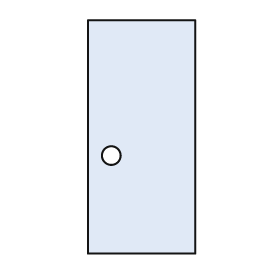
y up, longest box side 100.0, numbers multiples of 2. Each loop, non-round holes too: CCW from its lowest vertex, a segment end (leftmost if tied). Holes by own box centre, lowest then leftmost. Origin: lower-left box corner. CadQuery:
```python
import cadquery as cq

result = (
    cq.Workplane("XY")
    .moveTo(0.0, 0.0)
    .lineTo(46.0, 0.0)
    .lineTo(46.0, 100.0)
    .lineTo(0.0, 100.0)
    .close()
    .moveTo(10.0, 42.0)
    .circle(4.0)
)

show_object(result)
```